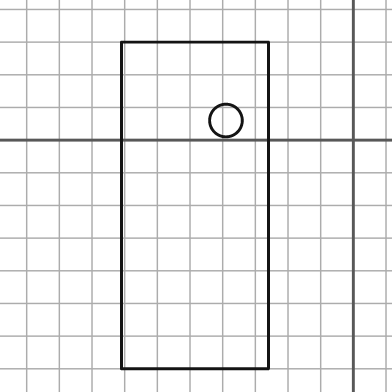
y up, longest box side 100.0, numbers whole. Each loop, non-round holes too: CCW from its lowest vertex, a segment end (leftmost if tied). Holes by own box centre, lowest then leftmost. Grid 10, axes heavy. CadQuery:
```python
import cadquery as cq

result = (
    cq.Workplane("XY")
    .moveTo(-71.0, -70.0)
    .lineTo(-26.0, -70.0)
    .lineTo(-26.0, 30.0)
    .lineTo(-71.0, 30.0)
    .close()
    .moveTo(-39.0, 6.0)
    .circle(5.0)
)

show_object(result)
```